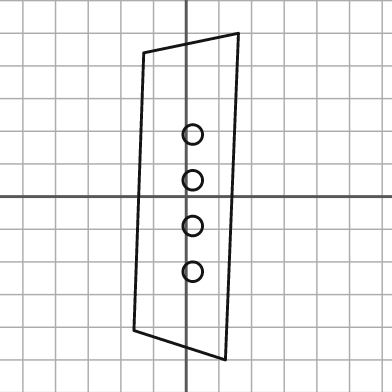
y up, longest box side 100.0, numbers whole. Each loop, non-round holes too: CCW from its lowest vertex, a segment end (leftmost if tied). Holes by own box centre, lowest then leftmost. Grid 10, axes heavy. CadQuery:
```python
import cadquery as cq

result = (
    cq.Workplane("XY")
    .moveTo(12.0, -50.0)
    .lineTo(16.0, 50.0)
    .lineTo(-13.0, 44.0)
    .lineTo(-16.0, -41.0)
    .close()
    .moveTo(2.0, -23.0)
    .circle(3.0)
    .moveTo(2.0, -9.0)
    .circle(3.0)
    .moveTo(2.0, 5.0)
    .circle(3.0)
    .moveTo(2.0, 19.0)
    .circle(3.0)
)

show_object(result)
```